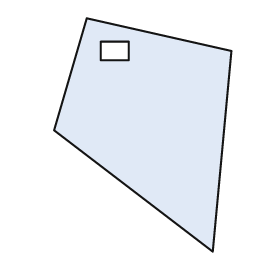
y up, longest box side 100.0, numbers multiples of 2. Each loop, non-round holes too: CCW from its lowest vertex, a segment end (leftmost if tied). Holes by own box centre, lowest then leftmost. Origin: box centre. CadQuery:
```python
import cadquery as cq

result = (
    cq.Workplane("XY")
    .moveTo(30.0, -50.0)
    .lineTo(38.0, 36.0)
    .lineTo(-24.0, 50.0)
    .lineTo(-38.0, 2.0)
    .close()
    .moveTo(-18.0, 32.0)
    .lineTo(-6.0, 32.0)
    .lineTo(-6.0, 40.0)
    .lineTo(-18.0, 40.0)
    .close()
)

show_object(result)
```